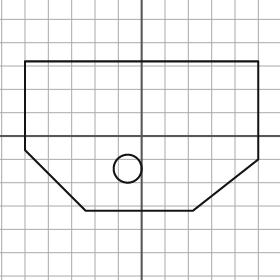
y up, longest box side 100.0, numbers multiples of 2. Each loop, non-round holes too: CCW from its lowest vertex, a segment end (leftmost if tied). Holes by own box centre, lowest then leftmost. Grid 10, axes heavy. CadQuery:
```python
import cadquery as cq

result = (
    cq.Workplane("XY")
    .moveTo(-24.0, -32.0)
    .lineTo(22.0, -32.0)
    .lineTo(50.0, -10.0)
    .lineTo(50.0, 32.0)
    .lineTo(-50.0, 32.0)
    .lineTo(-50.0, -6.0)
    .close()
    .moveTo(-6.0, -14.0)
    .circle(6.0)
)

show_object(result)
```